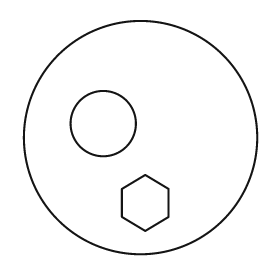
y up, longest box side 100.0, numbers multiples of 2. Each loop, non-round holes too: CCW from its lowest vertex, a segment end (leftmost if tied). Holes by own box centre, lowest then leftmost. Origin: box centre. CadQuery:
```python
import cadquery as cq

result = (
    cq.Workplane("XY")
    .moveTo(0.0, 0.0)
    .circle(50.0)
    .moveTo(2.0, -40.0)
    .lineTo(12.0, -34.0)
    .lineTo(12.0, -22.0)
    .lineTo(2.0, -16.0)
    .lineTo(-8.0, -22.0)
    .lineTo(-8.0, -34.0)
    .close()
    .moveTo(-16.0, 6.0)
    .circle(14.0)
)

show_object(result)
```